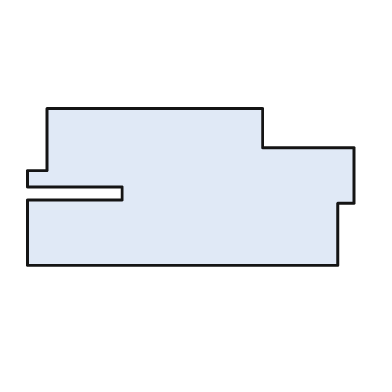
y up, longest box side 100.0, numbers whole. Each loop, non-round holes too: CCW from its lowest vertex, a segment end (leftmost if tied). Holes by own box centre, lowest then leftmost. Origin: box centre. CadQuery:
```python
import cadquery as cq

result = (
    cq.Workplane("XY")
    .moveTo(-50.0, -24.0)
    .lineTo(45.0, -24.0)
    .lineTo(45.0, -5.0)
    .lineTo(50.0, -5.0)
    .lineTo(50.0, 12.0)
    .lineTo(22.0, 12.0)
    .lineTo(22.0, 24.0)
    .lineTo(-44.0, 24.0)
    .lineTo(-44.0, 5.0)
    .lineTo(-50.0, 5.0)
    .lineTo(-50.0, 0.0)
    .lineTo(-21.0, 0.0)
    .lineTo(-21.0, -4.0)
    .lineTo(-50.0, -4.0)
    .close()
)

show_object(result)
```